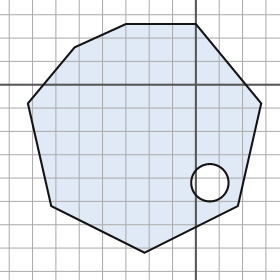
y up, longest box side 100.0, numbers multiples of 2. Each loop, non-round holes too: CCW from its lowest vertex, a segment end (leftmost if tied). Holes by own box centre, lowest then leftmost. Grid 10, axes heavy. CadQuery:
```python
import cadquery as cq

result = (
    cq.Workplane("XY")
    .moveTo(-22.0, -72.0)
    .lineTo(18.0, -52.0)
    .lineTo(28.0, -8.0)
    .lineTo(0.0, 26.0)
    .lineTo(-30.0, 26.0)
    .lineTo(-52.0, 16.0)
    .lineTo(-72.0, -8.0)
    .lineTo(-62.0, -52.0)
    .close()
    .moveTo(6.0, -42.0)
    .circle(8.0)
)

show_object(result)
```